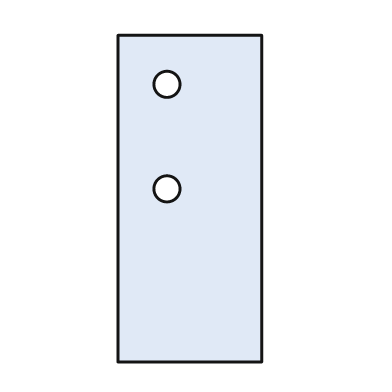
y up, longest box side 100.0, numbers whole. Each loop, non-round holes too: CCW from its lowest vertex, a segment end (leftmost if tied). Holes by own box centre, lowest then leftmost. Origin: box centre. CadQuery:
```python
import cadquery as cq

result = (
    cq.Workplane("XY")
    .moveTo(-22.0, -50.0)
    .lineTo(22.0, -50.0)
    .lineTo(22.0, 50.0)
    .lineTo(-22.0, 50.0)
    .close()
    .moveTo(-7.0, 3.0)
    .circle(4.0)
    .moveTo(-7.0, 35.0)
    .circle(4.0)
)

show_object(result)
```